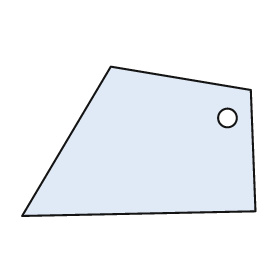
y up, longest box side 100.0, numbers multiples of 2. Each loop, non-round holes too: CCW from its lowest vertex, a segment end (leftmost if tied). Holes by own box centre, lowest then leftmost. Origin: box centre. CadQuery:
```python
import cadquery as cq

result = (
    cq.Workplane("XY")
    .moveTo(-50.0, -32.0)
    .lineTo(50.0, -30.0)
    .lineTo(48.0, 22.0)
    .lineTo(-12.0, 32.0)
    .close()
    .moveTo(38.0, 10.0)
    .circle(4.0)
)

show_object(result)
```